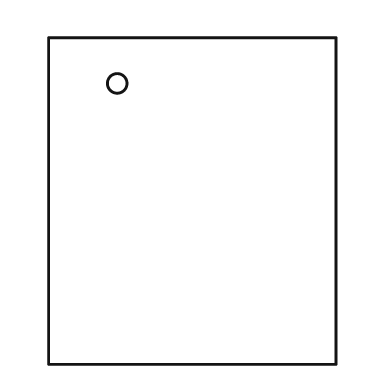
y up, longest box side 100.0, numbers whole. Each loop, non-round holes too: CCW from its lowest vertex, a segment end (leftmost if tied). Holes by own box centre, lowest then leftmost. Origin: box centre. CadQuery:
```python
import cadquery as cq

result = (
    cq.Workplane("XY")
    .moveTo(-44.0, -50.0)
    .lineTo(44.0, -50.0)
    .lineTo(44.0, 50.0)
    .lineTo(-44.0, 50.0)
    .close()
    .moveTo(-23.0, 36.0)
    .circle(3.0)
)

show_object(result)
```